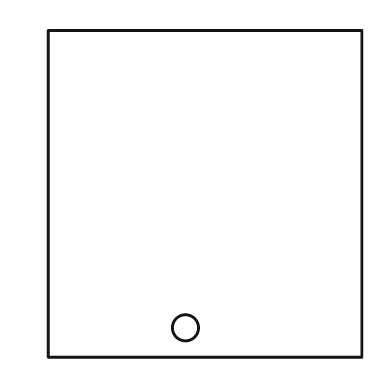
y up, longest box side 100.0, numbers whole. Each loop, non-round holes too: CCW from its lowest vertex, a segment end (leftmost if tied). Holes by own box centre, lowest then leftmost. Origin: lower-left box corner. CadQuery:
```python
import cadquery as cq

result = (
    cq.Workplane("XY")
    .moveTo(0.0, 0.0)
    .lineTo(96.0, 0.0)
    .lineTo(96.0, 100.0)
    .lineTo(0.0, 100.0)
    .close()
    .moveTo(42.0, 9.0)
    .circle(4.0)
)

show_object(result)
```